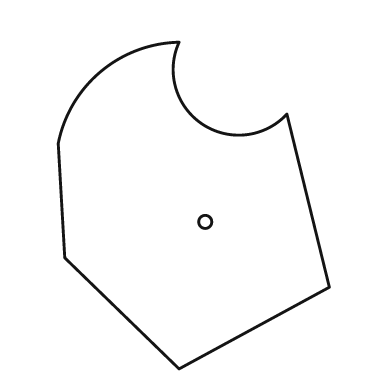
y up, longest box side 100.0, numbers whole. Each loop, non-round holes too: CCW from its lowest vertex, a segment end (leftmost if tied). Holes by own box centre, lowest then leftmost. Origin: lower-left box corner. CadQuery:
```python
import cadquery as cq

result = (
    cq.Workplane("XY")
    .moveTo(37.0, 0.0)
    .lineTo(83.0, 25.0)
    .lineTo(70.0, 78.0)
    .threePointArc((44.0, 75.0), (37.0, 100.0))
    .threePointArc((13.0, 91.0), (0.0, 69.0))
    .lineTo(2.0, 34.0)
    .close()
    .moveTo(45.0, 45.0)
    .circle(2.0)
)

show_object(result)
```